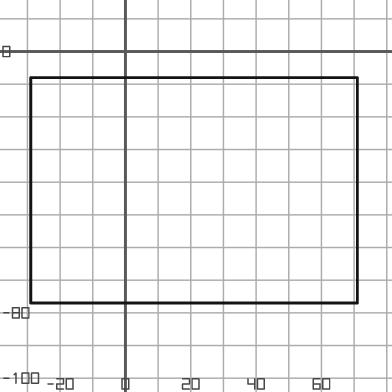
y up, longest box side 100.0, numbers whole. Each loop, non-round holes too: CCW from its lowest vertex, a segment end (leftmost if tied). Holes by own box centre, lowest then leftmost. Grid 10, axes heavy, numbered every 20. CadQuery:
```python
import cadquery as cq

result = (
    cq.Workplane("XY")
    .moveTo(-29.0, -77.0)
    .lineTo(71.0, -77.0)
    .lineTo(71.0, -8.0)
    .lineTo(-29.0, -8.0)
    .close()
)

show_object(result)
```